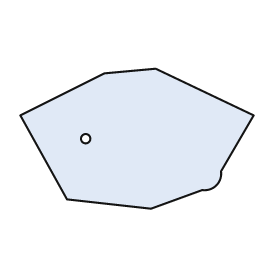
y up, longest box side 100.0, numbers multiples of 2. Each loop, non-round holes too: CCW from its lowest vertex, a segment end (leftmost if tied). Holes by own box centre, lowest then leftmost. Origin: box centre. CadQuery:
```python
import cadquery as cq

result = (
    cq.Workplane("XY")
    .moveTo(6.0, -30.0)
    .lineTo(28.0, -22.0)
    .threePointArc((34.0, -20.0), (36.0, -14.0))
    .lineTo(50.0, 10.0)
    .lineTo(8.0, 30.0)
    .lineTo(-14.0, 28.0)
    .lineTo(-50.0, 10.0)
    .lineTo(-30.0, -26.0)
    .close()
    .moveTo(-22.0, 0.0)
    .circle(2.0)
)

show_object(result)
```